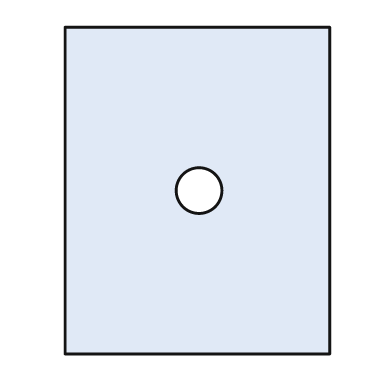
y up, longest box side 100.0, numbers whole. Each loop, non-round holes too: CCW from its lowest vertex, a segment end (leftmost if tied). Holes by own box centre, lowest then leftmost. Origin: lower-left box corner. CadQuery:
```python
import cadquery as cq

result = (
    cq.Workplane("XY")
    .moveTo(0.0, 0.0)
    .lineTo(81.0, 0.0)
    .lineTo(81.0, 100.0)
    .lineTo(0.0, 100.0)
    .close()
    .moveTo(41.0, 50.0)
    .circle(7.0)
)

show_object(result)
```